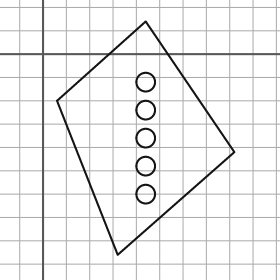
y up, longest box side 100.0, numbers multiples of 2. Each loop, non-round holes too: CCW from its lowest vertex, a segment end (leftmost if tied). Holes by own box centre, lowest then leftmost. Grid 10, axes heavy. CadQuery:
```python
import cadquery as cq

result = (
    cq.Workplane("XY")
    .moveTo(32.0, -86.0)
    .lineTo(82.0, -42.0)
    .lineTo(44.0, 14.0)
    .lineTo(6.0, -20.0)
    .close()
    .moveTo(44.0, -60.0)
    .circle(4.0)
    .moveTo(44.0, -48.0)
    .circle(4.0)
    .moveTo(44.0, -36.0)
    .circle(4.0)
    .moveTo(44.0, -24.0)
    .circle(4.0)
    .moveTo(44.0, -12.0)
    .circle(4.0)
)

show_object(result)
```